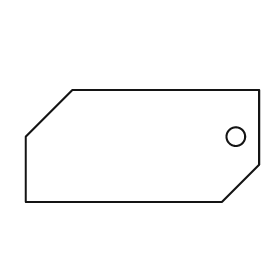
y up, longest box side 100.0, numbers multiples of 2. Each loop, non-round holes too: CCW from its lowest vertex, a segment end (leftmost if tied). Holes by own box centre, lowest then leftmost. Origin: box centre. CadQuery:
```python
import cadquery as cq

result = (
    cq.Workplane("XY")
    .moveTo(-50.0, -24.0)
    .lineTo(34.0, -24.0)
    .lineTo(50.0, -8.0)
    .lineTo(50.0, 24.0)
    .lineTo(-30.0, 24.0)
    .lineTo(-50.0, 4.0)
    .close()
    .moveTo(40.0, 4.0)
    .circle(4.0)
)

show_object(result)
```